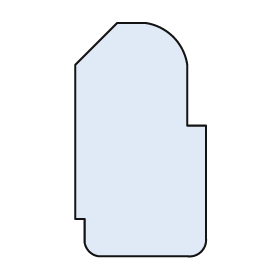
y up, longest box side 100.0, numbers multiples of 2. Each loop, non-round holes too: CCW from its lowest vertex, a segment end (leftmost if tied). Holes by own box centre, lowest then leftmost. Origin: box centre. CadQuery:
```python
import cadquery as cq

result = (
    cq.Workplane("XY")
    .moveTo(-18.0, -50.0)
    .lineTo(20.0, -50.0)
    .threePointArc((26.0, -48.0), (28.0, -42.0))
    .lineTo(28.0, 6.0)
    .lineTo(20.0, 6.0)
    .lineTo(20.0, 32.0)
    .threePointArc((14.0, 44.0), (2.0, 50.0))
    .lineTo(-10.0, 50.0)
    .lineTo(-28.0, 32.0)
    .lineTo(-28.0, -34.0)
    .lineTo(-24.0, -34.0)
    .lineTo(-24.0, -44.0)
    .threePointArc((-22.0, -48.0), (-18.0, -50.0))
    .close()
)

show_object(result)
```